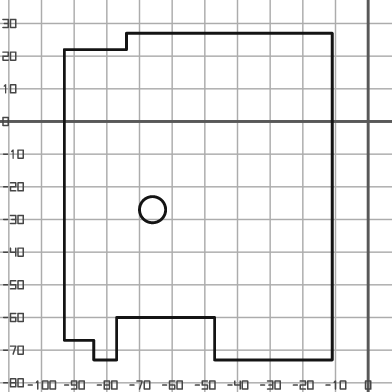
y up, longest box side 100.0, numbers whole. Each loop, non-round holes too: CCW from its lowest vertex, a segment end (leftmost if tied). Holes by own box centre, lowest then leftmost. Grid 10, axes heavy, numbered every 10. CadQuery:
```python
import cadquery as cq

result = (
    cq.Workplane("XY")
    .moveTo(-84.0, -73.0)
    .lineTo(-77.0, -73.0)
    .lineTo(-77.0, -60.0)
    .lineTo(-47.0, -60.0)
    .lineTo(-47.0, -73.0)
    .lineTo(-11.0, -73.0)
    .lineTo(-11.0, 27.0)
    .lineTo(-74.0, 27.0)
    .lineTo(-74.0, 22.0)
    .lineTo(-93.0, 22.0)
    .lineTo(-93.0, -67.0)
    .lineTo(-84.0, -67.0)
    .close()
    .moveTo(-66.0, -27.0)
    .circle(4.0)
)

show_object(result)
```